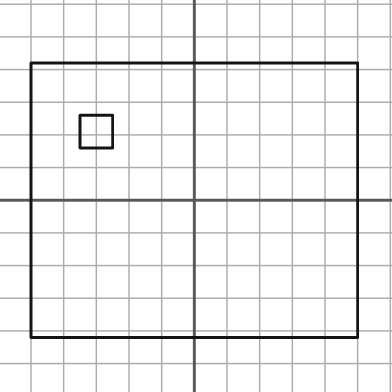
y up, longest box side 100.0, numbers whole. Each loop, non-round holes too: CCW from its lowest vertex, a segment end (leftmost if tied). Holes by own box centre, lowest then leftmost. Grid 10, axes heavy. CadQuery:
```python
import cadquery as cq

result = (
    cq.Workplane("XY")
    .moveTo(-50.0, -42.0)
    .lineTo(50.0, -42.0)
    .lineTo(50.0, 42.0)
    .lineTo(-50.0, 42.0)
    .close()
    .moveTo(-35.0, 16.0)
    .lineTo(-25.0, 16.0)
    .lineTo(-25.0, 26.0)
    .lineTo(-35.0, 26.0)
    .close()
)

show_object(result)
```